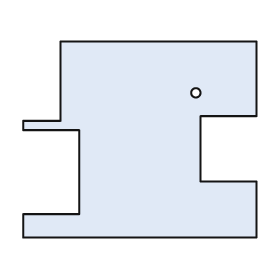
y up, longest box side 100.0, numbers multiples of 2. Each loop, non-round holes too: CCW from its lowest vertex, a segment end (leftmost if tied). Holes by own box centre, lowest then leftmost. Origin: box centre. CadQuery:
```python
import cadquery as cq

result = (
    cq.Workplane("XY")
    .moveTo(-50.0, -42.0)
    .lineTo(50.0, -42.0)
    .lineTo(50.0, -18.0)
    .lineTo(26.0, -18.0)
    .lineTo(26.0, 10.0)
    .lineTo(50.0, 10.0)
    .lineTo(50.0, 42.0)
    .lineTo(-34.0, 42.0)
    .lineTo(-34.0, 8.0)
    .lineTo(-50.0, 8.0)
    .lineTo(-50.0, 4.0)
    .lineTo(-26.0, 4.0)
    .lineTo(-26.0, -32.0)
    .lineTo(-50.0, -32.0)
    .close()
    .moveTo(24.0, 20.0)
    .circle(2.0)
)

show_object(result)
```